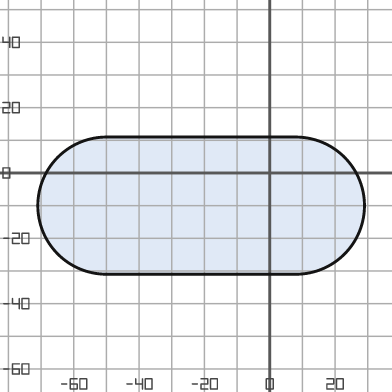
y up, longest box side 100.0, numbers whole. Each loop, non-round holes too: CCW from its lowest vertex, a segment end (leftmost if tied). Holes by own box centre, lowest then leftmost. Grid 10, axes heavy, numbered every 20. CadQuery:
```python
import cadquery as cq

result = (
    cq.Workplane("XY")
    .moveTo(-50.0, -31.0)
    .lineTo(8.0, -31.0)
    .threePointArc((29.0, -10.0), (8.0, 11.0))
    .lineTo(-50.0, 11.0)
    .threePointArc((-71.0, -10.0), (-50.0, -31.0))
    .close()
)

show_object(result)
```